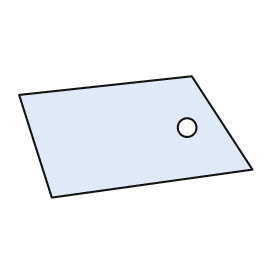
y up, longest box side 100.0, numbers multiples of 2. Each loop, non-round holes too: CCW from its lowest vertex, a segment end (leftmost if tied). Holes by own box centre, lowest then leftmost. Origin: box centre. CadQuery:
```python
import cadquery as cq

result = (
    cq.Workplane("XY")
    .moveTo(-36.0, -26.0)
    .lineTo(50.0, -14.0)
    .lineTo(24.0, 26.0)
    .lineTo(-50.0, 18.0)
    .close()
    .moveTo(22.0, 4.0)
    .circle(4.0)
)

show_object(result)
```